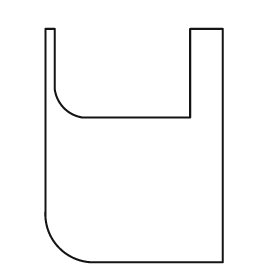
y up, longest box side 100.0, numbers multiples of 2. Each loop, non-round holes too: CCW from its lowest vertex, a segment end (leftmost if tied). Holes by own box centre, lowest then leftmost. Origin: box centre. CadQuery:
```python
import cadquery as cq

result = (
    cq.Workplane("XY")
    .moveTo(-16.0, -50.0)
    .lineTo(38.0, -50.0)
    .lineTo(38.0, 50.0)
    .lineTo(24.0, 50.0)
    .lineTo(24.0, 12.0)
    .lineTo(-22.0, 12.0)
    .threePointArc((-30.0, 16.0), (-34.0, 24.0))
    .lineTo(-34.0, 50.0)
    .lineTo(-38.0, 50.0)
    .lineTo(-38.0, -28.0)
    .threePointArc((-32.0, -44.0), (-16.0, -50.0))
    .close()
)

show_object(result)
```